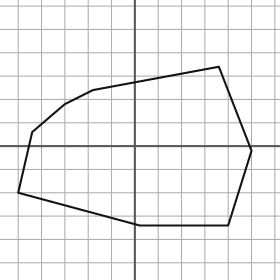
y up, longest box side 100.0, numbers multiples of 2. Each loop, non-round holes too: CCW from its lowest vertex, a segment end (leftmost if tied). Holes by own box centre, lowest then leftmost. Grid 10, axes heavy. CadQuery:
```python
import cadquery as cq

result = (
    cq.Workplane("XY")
    .moveTo(2.0, -34.0)
    .lineTo(40.0, -34.0)
    .lineTo(50.0, -2.0)
    .lineTo(36.0, 34.0)
    .lineTo(-18.0, 24.0)
    .lineTo(-30.0, 18.0)
    .lineTo(-44.0, 6.0)
    .lineTo(-50.0, -20.0)
    .close()
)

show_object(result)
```